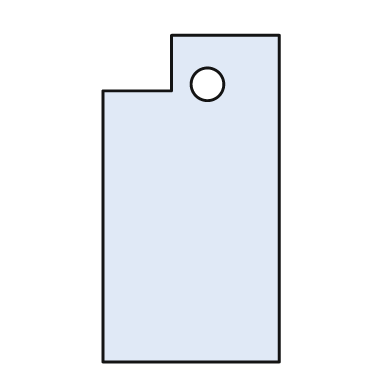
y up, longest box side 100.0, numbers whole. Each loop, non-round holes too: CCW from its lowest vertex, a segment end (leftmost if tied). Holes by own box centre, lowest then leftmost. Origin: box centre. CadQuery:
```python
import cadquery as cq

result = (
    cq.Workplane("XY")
    .moveTo(-27.0, -50.0)
    .lineTo(27.0, -50.0)
    .lineTo(27.0, 50.0)
    .lineTo(-6.0, 50.0)
    .lineTo(-6.0, 33.0)
    .lineTo(-27.0, 33.0)
    .close()
    .moveTo(5.0, 35.0)
    .circle(5.0)
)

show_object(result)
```